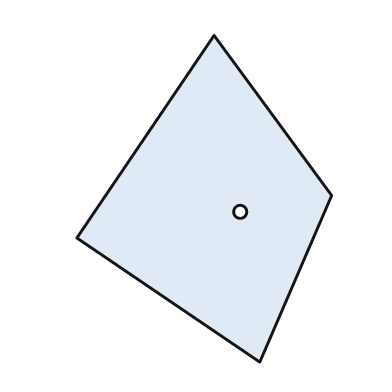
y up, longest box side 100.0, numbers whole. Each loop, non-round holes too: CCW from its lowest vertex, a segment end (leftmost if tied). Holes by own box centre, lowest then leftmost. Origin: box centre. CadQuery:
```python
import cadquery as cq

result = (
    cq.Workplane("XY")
    .moveTo(17.0, -50.0)
    .lineTo(39.0, 1.0)
    .lineTo(3.0, 50.0)
    .lineTo(-39.0, -12.0)
    .close()
    .moveTo(11.0, -4.0)
    .circle(2.0)
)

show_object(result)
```